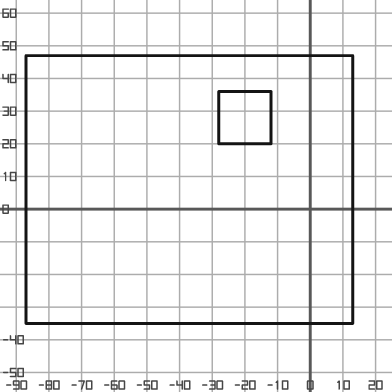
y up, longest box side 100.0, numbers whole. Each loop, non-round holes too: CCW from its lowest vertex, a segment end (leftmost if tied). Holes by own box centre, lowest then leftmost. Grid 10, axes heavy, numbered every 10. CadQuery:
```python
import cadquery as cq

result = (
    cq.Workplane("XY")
    .moveTo(-87.0, -35.0)
    .lineTo(13.0, -35.0)
    .lineTo(13.0, 47.0)
    .lineTo(-87.0, 47.0)
    .close()
    .moveTo(-28.0, 20.0)
    .lineTo(-12.0, 20.0)
    .lineTo(-12.0, 36.0)
    .lineTo(-28.0, 36.0)
    .close()
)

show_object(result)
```